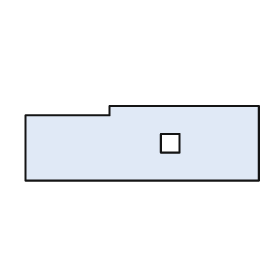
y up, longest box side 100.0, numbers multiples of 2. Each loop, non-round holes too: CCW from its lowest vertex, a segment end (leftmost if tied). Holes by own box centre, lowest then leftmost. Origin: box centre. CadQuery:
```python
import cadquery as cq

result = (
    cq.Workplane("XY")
    .moveTo(-50.0, -16.0)
    .lineTo(50.0, -16.0)
    .lineTo(50.0, 16.0)
    .lineTo(-14.0, 16.0)
    .lineTo(-14.0, 12.0)
    .lineTo(-50.0, 12.0)
    .close()
    .moveTo(8.0, -4.0)
    .lineTo(16.0, -4.0)
    .lineTo(16.0, 4.0)
    .lineTo(8.0, 4.0)
    .close()
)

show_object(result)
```